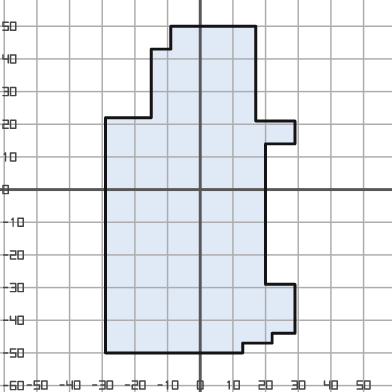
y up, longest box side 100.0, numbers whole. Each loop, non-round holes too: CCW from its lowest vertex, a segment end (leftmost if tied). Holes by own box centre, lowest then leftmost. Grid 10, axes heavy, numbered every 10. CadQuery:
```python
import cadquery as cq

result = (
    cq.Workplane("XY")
    .moveTo(-29.0, -50.0)
    .lineTo(13.0, -50.0)
    .lineTo(13.0, -47.0)
    .lineTo(22.0, -47.0)
    .lineTo(22.0, -44.0)
    .lineTo(29.0, -44.0)
    .lineTo(29.0, -29.0)
    .lineTo(20.0, -29.0)
    .lineTo(20.0, 14.0)
    .lineTo(29.0, 14.0)
    .lineTo(29.0, 21.0)
    .lineTo(17.0, 21.0)
    .lineTo(17.0, 50.0)
    .lineTo(-9.0, 50.0)
    .lineTo(-9.0, 43.0)
    .lineTo(-15.0, 43.0)
    .lineTo(-15.0, 22.0)
    .lineTo(-29.0, 22.0)
    .close()
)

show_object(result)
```